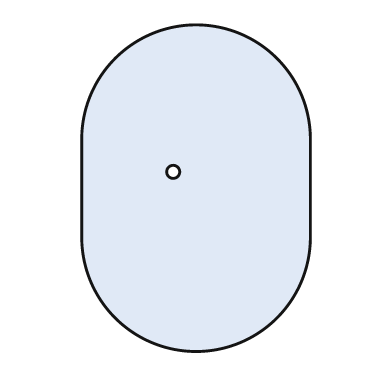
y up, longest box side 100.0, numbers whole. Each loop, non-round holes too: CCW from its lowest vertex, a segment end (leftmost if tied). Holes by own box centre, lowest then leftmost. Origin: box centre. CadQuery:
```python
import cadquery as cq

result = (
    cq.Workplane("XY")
    .moveTo(-35.0, -15.0)
    .threePointArc((0.0, -50.0), (35.0, -15.0))
    .lineTo(35.0, 15.0)
    .threePointArc((0.0, 50.0), (-35.0, 15.0))
    .close()
    .moveTo(-7.0, 5.0)
    .circle(2.0)
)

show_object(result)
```